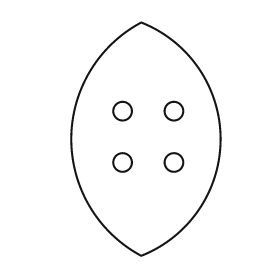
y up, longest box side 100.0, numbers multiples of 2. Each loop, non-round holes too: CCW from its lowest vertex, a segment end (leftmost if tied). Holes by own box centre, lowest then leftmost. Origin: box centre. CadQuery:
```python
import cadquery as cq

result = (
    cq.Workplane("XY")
    .moveTo(-2.0, -50.0)
    .threePointArc((32.0, 0.0), (-2.0, 50.0))
    .threePointArc((-32.0, 0.0), (-2.0, -50.0))
    .close()
    .moveTo(-10.0, -10.0)
    .circle(4.0)
    .moveTo(12.0, -10.0)
    .circle(4.0)
    .moveTo(-10.0, 12.0)
    .circle(4.0)
    .moveTo(12.0, 12.0)
    .circle(4.0)
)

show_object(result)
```